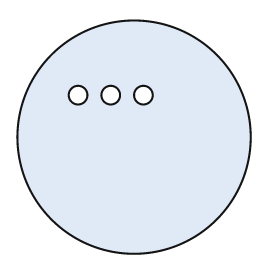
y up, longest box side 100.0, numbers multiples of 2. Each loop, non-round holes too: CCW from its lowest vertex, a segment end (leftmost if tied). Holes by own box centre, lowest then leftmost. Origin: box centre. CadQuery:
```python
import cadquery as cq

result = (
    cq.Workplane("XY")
    .moveTo(0.0, 0.0)
    .circle(50.0)
    .moveTo(-24.0, 18.0)
    .circle(4.0)
    .moveTo(-10.0, 18.0)
    .circle(4.0)
    .moveTo(4.0, 18.0)
    .circle(4.0)
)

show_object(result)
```